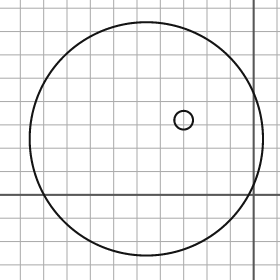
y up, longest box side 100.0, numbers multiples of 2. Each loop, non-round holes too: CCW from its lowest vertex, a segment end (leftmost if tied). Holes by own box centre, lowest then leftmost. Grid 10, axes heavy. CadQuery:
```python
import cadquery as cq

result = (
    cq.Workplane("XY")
    .moveTo(-46.0, 24.0)
    .circle(50.0)
    .moveTo(-30.0, 32.0)
    .circle(4.0)
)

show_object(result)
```